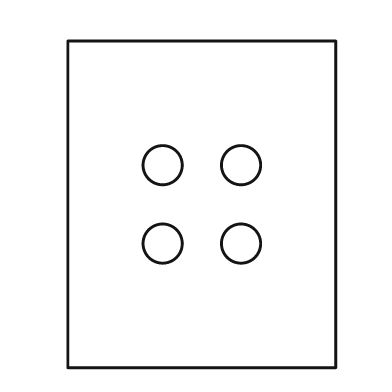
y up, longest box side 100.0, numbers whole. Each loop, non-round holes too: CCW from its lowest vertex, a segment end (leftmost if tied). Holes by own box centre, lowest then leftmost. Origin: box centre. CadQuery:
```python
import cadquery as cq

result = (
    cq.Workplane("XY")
    .moveTo(-41.0, -50.0)
    .lineTo(41.0, -50.0)
    .lineTo(41.0, 50.0)
    .lineTo(-41.0, 50.0)
    .close()
    .moveTo(-12.0, -12.0)
    .circle(6.0)
    .moveTo(12.0, -12.0)
    .circle(6.0)
    .moveTo(-12.0, 12.0)
    .circle(6.0)
    .moveTo(12.0, 12.0)
    .circle(6.0)
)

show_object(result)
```